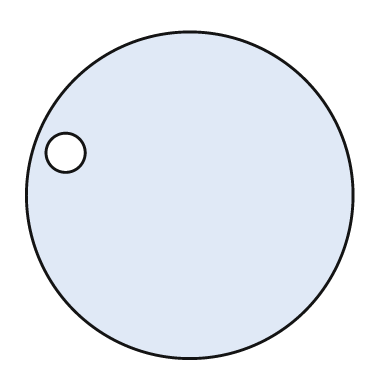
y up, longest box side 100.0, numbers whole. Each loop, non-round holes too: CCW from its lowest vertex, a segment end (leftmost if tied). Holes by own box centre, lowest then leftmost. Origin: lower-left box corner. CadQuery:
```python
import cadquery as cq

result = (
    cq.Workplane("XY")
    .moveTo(50.0, 50.0)
    .circle(50.0)
    .moveTo(12.0, 63.0)
    .circle(6.0)
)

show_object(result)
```